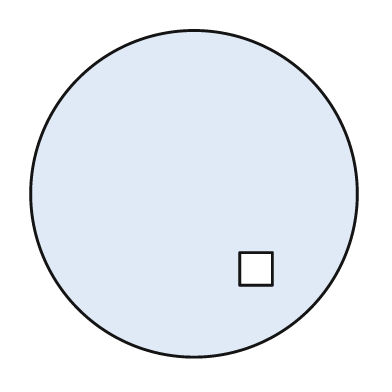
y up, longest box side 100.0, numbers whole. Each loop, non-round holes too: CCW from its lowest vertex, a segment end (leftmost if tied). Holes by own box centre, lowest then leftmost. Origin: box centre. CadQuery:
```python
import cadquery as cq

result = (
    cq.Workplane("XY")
    .moveTo(0.0, 0.0)
    .circle(50.0)
    .moveTo(14.0, -28.0)
    .lineTo(24.0, -28.0)
    .lineTo(24.0, -18.0)
    .lineTo(14.0, -18.0)
    .close()
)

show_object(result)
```